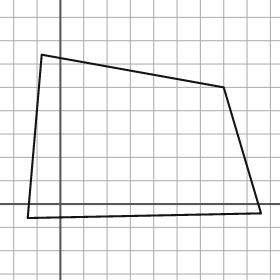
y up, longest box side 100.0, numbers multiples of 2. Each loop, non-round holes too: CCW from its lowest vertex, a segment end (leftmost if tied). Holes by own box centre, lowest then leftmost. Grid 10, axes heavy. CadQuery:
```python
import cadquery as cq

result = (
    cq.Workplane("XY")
    .moveTo(-14.0, -6.0)
    .lineTo(86.0, -4.0)
    .lineTo(70.0, 50.0)
    .lineTo(-8.0, 64.0)
    .close()
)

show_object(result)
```